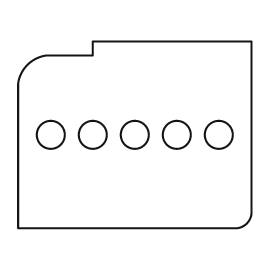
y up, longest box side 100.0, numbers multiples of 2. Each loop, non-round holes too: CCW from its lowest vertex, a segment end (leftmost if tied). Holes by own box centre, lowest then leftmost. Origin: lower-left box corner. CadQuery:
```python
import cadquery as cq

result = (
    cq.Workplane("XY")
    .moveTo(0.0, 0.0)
    .lineTo(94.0, 0.0)
    .threePointArc((98.0, 2.0), (100.0, 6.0))
    .lineTo(100.0, 80.0)
    .lineTo(32.0, 80.0)
    .lineTo(32.0, 74.0)
    .lineTo(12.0, 74.0)
    .threePointArc((4.0, 70.0), (0.0, 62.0))
    .close()
    .moveTo(14.0, 40.0)
    .circle(6.0)
    .moveTo(32.0, 40.0)
    .circle(6.0)
    .moveTo(50.0, 40.0)
    .circle(6.0)
    .moveTo(68.0, 40.0)
    .circle(6.0)
    .moveTo(86.0, 40.0)
    .circle(6.0)
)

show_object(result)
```